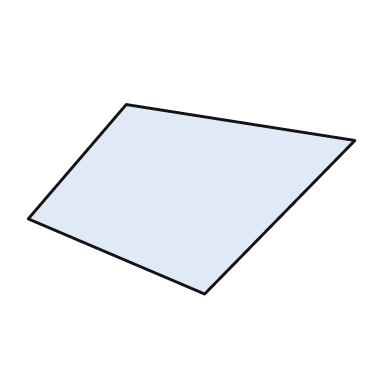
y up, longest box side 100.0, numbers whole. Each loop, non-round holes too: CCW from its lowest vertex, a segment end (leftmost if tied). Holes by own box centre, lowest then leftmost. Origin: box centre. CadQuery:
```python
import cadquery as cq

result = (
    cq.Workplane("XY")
    .moveTo(4.0, -29.0)
    .lineTo(50.0, 18.0)
    .lineTo(-20.0, 29.0)
    .lineTo(-50.0, -6.0)
    .close()
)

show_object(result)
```